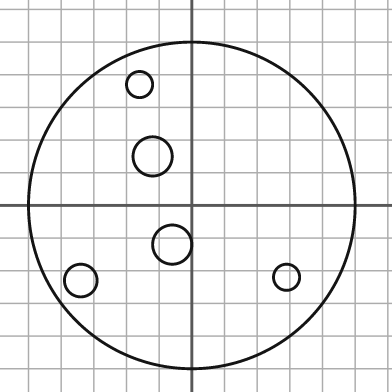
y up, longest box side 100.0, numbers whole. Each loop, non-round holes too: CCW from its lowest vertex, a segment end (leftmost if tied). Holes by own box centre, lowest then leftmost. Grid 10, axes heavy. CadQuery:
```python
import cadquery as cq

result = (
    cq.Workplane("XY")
    .moveTo(0.0, 0.0)
    .circle(50.0)
    .moveTo(-34.0, -23.0)
    .circle(5.0)
    .moveTo(29.0, -22.0)
    .circle(4.0)
    .moveTo(-6.0, -12.0)
    .circle(6.0)
    .moveTo(-12.0, 15.0)
    .circle(6.0)
    .moveTo(-16.0, 37.0)
    .circle(4.0)
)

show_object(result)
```